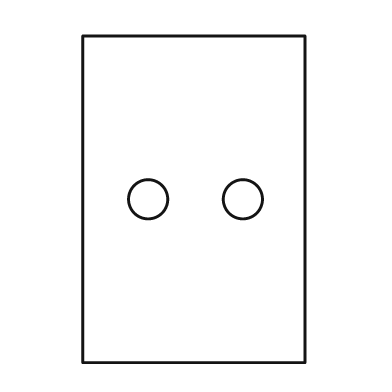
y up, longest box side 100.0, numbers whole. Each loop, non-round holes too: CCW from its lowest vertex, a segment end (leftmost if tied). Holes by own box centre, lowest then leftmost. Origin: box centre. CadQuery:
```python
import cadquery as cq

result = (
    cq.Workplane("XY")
    .moveTo(-34.0, -50.0)
    .lineTo(34.0, -50.0)
    .lineTo(34.0, 50.0)
    .lineTo(-34.0, 50.0)
    .close()
    .moveTo(-14.0, 0.0)
    .circle(6.0)
    .moveTo(15.0, 0.0)
    .circle(6.0)
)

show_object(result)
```